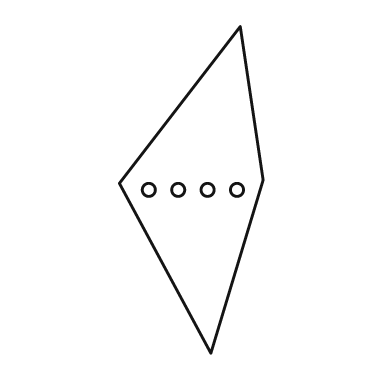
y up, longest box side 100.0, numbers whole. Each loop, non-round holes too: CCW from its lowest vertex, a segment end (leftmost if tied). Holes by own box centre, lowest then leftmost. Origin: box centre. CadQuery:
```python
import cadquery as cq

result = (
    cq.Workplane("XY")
    .moveTo(6.0, -50.0)
    .lineTo(22.0, 3.0)
    .lineTo(15.0, 50.0)
    .lineTo(-22.0, 2.0)
    .close()
    .moveTo(-13.0, 0.0)
    .circle(2.0)
    .moveTo(-4.0, 0.0)
    .circle(2.0)
    .moveTo(5.0, 0.0)
    .circle(2.0)
    .moveTo(14.0, 0.0)
    .circle(2.0)
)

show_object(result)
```